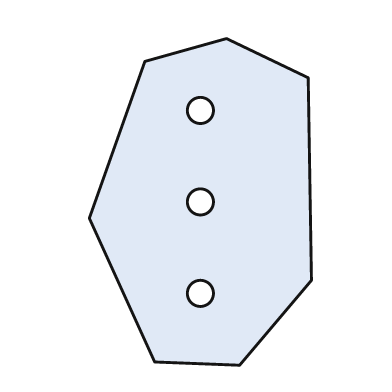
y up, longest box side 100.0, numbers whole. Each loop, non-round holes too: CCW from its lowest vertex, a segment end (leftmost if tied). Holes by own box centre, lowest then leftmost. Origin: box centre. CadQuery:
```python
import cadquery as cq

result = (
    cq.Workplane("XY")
    .moveTo(12.0, -50.0)
    .lineTo(34.0, -24.0)
    .lineTo(33.0, 38.0)
    .lineTo(8.0, 50.0)
    .lineTo(-17.0, 43.0)
    .lineTo(-34.0, -5.0)
    .lineTo(-14.0, -49.0)
    .close()
    .moveTo(0.0, -28.0)
    .circle(4.0)
    .moveTo(0.0, 0.0)
    .circle(4.0)
    .moveTo(0.0, 28.0)
    .circle(4.0)
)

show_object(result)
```